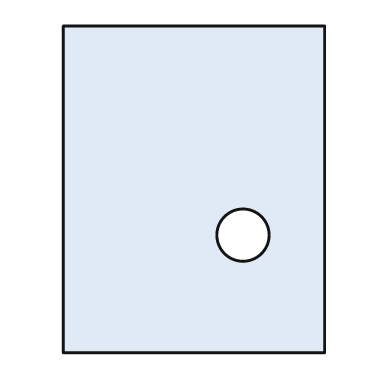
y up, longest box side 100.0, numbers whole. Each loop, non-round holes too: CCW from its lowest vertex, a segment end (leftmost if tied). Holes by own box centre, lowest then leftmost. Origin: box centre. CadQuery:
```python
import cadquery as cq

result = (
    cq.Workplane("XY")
    .moveTo(-40.0, -50.0)
    .lineTo(40.0, -50.0)
    .lineTo(40.0, 50.0)
    .lineTo(-40.0, 50.0)
    .close()
    .moveTo(15.0, -14.0)
    .circle(8.0)
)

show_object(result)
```